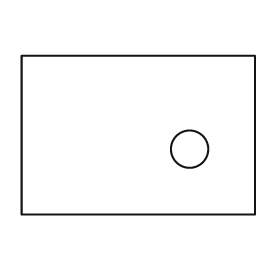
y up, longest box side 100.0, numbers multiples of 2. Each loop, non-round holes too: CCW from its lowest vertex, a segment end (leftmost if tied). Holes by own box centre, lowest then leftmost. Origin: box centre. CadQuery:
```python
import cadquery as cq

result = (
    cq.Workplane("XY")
    .moveTo(-50.0, -34.0)
    .lineTo(50.0, -34.0)
    .lineTo(50.0, 34.0)
    .lineTo(-50.0, 34.0)
    .close()
    .moveTo(22.0, -6.0)
    .circle(8.0)
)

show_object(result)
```